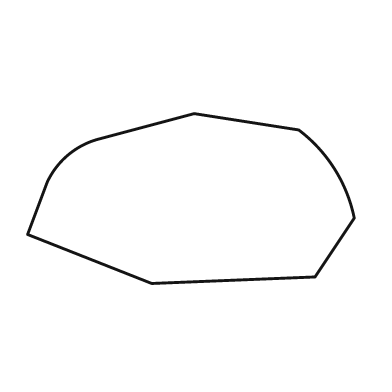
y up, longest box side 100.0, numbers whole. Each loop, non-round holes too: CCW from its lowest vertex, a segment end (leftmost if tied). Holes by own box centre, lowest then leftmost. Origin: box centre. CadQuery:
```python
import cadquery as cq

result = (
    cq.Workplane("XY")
    .moveTo(-12.0, -26.0)
    .lineTo(38.0, -24.0)
    .lineTo(50.0, -6.0)
    .threePointArc((44.0, 9.0), (33.0, 21.0))
    .lineTo(1.0, 26.0)
    .lineTo(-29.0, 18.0)
    .threePointArc((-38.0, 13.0), (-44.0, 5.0))
    .lineTo(-50.0, -11.0)
    .close()
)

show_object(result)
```